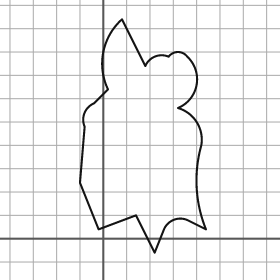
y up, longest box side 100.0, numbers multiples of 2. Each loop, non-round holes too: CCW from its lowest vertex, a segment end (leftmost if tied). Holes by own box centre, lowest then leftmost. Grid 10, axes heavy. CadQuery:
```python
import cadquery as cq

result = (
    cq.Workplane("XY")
    .moveTo(22.0, -6.0)
    .lineTo(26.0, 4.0)
    .threePointArc((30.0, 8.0), (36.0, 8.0))
    .lineTo(44.0, 4.0)
    .threePointArc((40.0, 22.0), (42.0, 40.0))
    .threePointArc((40.0, 50.0), (32.0, 56.0))
    .threePointArc((40.0, 66.0), (36.0, 78.0))
    .threePointArc((32.0, 80.0), (28.0, 78.0))
    .threePointArc((22.0, 78.0), (18.0, 74.0))
    .lineTo(8.0, 94.0)
    .threePointArc((0.0, 80.0), (2.0, 64.0))
    .lineTo(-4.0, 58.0)
    .threePointArc((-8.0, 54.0), (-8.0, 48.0))
    .lineTo(-10.0, 24.0)
    .lineTo(-2.0, 4.0)
    .lineTo(14.0, 10.0)
    .close()
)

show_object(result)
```